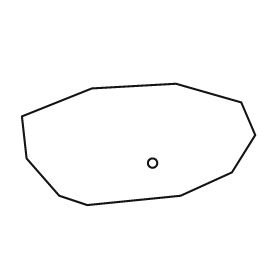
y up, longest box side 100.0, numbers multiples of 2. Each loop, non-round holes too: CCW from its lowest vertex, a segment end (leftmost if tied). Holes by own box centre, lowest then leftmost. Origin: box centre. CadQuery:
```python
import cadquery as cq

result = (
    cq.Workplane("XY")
    .moveTo(-22.0, -26.0)
    .lineTo(18.0, -22.0)
    .lineTo(40.0, -12.0)
    .lineTo(50.0, 4.0)
    .lineTo(44.0, 18.0)
    .lineTo(16.0, 26.0)
    .lineTo(-20.0, 24.0)
    .lineTo(-50.0, 12.0)
    .lineTo(-48.0, -6.0)
    .lineTo(-34.0, -22.0)
    .close()
    .moveTo(6.0, -8.0)
    .circle(2.0)
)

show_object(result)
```